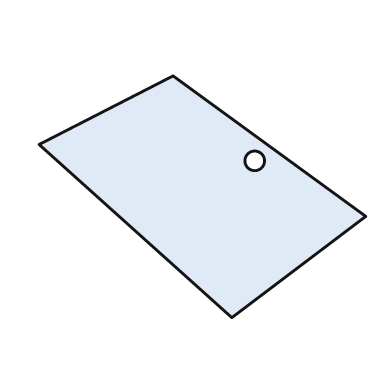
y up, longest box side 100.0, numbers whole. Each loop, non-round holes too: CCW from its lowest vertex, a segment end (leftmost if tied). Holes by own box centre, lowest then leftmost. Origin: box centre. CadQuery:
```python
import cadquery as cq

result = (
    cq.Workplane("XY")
    .moveTo(9.0, -37.0)
    .lineTo(50.0, -6.0)
    .lineTo(-9.0, 37.0)
    .lineTo(-50.0, 16.0)
    .close()
    .moveTo(16.0, 11.0)
    .circle(3.0)
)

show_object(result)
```